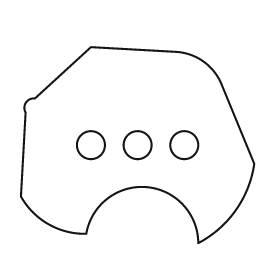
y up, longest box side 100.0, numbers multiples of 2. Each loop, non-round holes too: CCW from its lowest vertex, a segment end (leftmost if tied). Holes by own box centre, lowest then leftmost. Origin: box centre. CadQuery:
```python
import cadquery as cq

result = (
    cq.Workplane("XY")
    .moveTo(26.0, -42.0)
    .threePointArc((42.0, -28.0), (50.0, -8.0))
    .lineTo(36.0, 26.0)
    .threePointArc((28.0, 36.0), (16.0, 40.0))
    .lineTo(-20.0, 42.0)
    .lineTo(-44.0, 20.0)
    .threePointArc((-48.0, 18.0), (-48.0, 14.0))
    .lineTo(-50.0, -22.0)
    .threePointArc((-38.0, -34.0), (-22.0, -38.0))
    .threePointArc((4.0, -18.0), (26.0, -42.0))
    .close()
    .moveTo(-20.0, 0.0)
    .circle(6.0)
    .moveTo(0.0, 0.0)
    .circle(6.0)
    .moveTo(20.0, 0.0)
    .circle(6.0)
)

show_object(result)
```